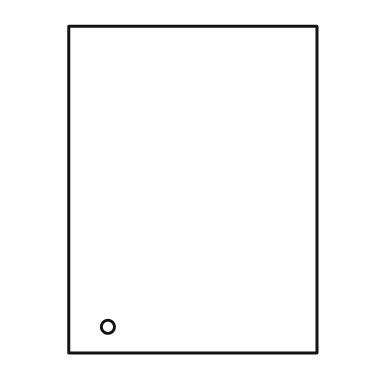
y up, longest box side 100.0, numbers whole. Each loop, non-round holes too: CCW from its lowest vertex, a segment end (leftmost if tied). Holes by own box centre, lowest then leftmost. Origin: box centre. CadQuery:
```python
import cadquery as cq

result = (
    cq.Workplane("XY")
    .moveTo(-38.0, -50.0)
    .lineTo(38.0, -50.0)
    .lineTo(38.0, 50.0)
    .lineTo(-38.0, 50.0)
    .close()
    .moveTo(-26.0, -42.0)
    .circle(2.0)
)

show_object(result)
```